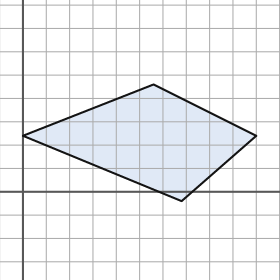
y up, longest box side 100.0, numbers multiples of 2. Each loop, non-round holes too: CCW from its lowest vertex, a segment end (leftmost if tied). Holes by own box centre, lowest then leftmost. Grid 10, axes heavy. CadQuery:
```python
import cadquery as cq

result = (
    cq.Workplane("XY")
    .moveTo(68.0, -4.0)
    .lineTo(100.0, 24.0)
    .lineTo(56.0, 46.0)
    .lineTo(0.0, 24.0)
    .close()
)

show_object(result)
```